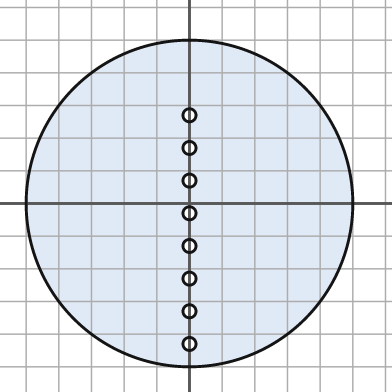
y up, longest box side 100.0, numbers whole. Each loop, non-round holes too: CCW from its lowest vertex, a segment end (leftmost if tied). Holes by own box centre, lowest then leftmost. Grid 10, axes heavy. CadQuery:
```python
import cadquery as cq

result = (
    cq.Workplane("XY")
    .moveTo(0.0, 0.0)
    .circle(50.0)
    .moveTo(0.0, -43.0)
    .circle(2.0)
    .moveTo(0.0, -33.0)
    .circle(2.0)
    .moveTo(0.0, -23.0)
    .circle(2.0)
    .moveTo(0.0, -13.0)
    .circle(2.0)
    .moveTo(0.0, -3.0)
    .circle(2.0)
    .moveTo(0.0, 7.0)
    .circle(2.0)
    .moveTo(0.0, 17.0)
    .circle(2.0)
    .moveTo(0.0, 27.0)
    .circle(2.0)
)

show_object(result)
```